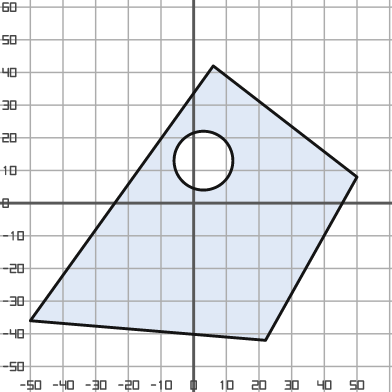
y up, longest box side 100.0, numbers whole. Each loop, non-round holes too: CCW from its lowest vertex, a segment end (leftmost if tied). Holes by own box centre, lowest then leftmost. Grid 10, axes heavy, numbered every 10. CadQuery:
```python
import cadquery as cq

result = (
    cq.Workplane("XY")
    .moveTo(22.0, -42.0)
    .lineTo(50.0, 8.0)
    .lineTo(6.0, 42.0)
    .lineTo(-50.0, -36.0)
    .close()
    .moveTo(3.0, 13.0)
    .circle(9.0)
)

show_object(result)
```